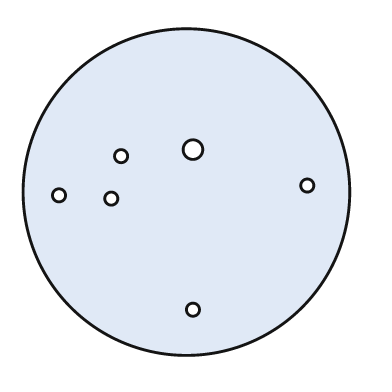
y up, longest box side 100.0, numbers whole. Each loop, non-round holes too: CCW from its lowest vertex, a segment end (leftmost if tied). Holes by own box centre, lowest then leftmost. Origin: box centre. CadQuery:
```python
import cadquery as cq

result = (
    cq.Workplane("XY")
    .moveTo(0.0, 0.0)
    .circle(50.0)
    .moveTo(2.0, -36.0)
    .circle(2.0)
    .moveTo(-23.0, -2.0)
    .circle(2.0)
    .moveTo(-39.0, -1.0)
    .circle(2.0)
    .moveTo(37.0, 2.0)
    .circle(2.0)
    .moveTo(-20.0, 11.0)
    .circle(2.0)
    .moveTo(2.0, 13.0)
    .circle(3.0)
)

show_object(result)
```